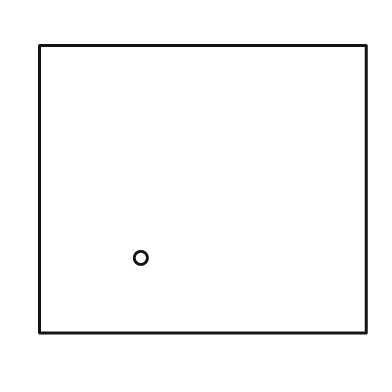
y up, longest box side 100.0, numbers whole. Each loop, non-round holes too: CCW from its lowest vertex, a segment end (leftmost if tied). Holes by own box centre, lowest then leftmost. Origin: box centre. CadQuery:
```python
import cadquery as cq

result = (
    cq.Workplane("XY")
    .moveTo(-50.0, -44.0)
    .lineTo(50.0, -44.0)
    .lineTo(50.0, 44.0)
    .lineTo(-50.0, 44.0)
    .close()
    .moveTo(-19.0, -21.0)
    .circle(2.0)
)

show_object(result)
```